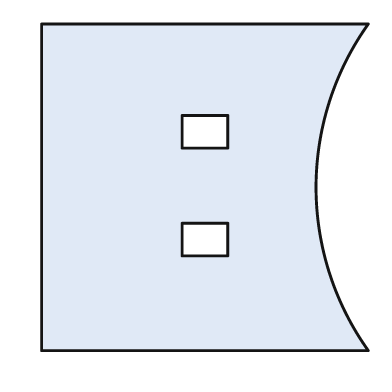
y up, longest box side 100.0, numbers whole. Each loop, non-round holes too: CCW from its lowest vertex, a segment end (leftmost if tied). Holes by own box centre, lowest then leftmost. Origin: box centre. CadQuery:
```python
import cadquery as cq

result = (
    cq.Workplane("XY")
    .moveTo(-50.0, -50.0)
    .lineTo(50.0, -50.0)
    .threePointArc((34.0, 0.0), (50.0, 50.0))
    .lineTo(-50.0, 50.0)
    .close()
    .moveTo(-7.0, -21.0)
    .lineTo(7.0, -21.0)
    .lineTo(7.0, -11.0)
    .lineTo(-7.0, -11.0)
    .close()
    .moveTo(-7.0, 12.0)
    .lineTo(7.0, 12.0)
    .lineTo(7.0, 22.0)
    .lineTo(-7.0, 22.0)
    .close()
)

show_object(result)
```